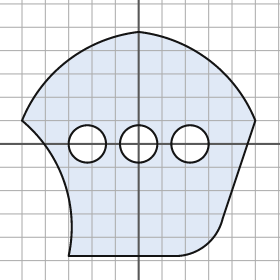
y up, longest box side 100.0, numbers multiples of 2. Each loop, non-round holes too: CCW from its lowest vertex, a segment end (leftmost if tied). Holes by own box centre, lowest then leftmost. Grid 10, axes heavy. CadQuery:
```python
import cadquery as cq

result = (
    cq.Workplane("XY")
    .moveTo(-30.0, -48.0)
    .lineTo(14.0, -48.0)
    .threePointArc((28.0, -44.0), (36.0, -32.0))
    .lineTo(50.0, 10.0)
    .threePointArc((30.0, 36.0), (0.0, 48.0))
    .threePointArc((-30.0, 36.0), (-50.0, 10.0))
    .threePointArc((-32.0, -16.0), (-30.0, -48.0))
    .close()
    .moveTo(-22.0, 0.0)
    .circle(8.0)
    .moveTo(0.0, 0.0)
    .circle(8.0)
    .moveTo(22.0, 0.0)
    .circle(8.0)
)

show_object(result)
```